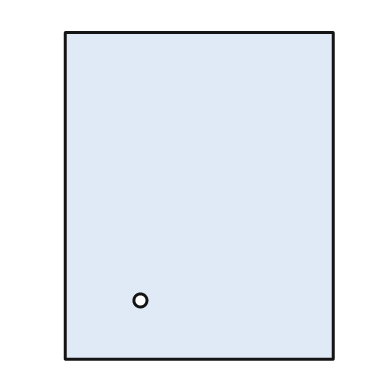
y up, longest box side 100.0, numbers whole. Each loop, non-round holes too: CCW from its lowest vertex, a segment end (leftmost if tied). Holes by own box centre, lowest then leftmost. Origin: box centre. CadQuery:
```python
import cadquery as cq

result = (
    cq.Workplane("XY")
    .moveTo(-41.0, -50.0)
    .lineTo(41.0, -50.0)
    .lineTo(41.0, 50.0)
    .lineTo(-41.0, 50.0)
    .close()
    .moveTo(-18.0, -32.0)
    .circle(2.0)
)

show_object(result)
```